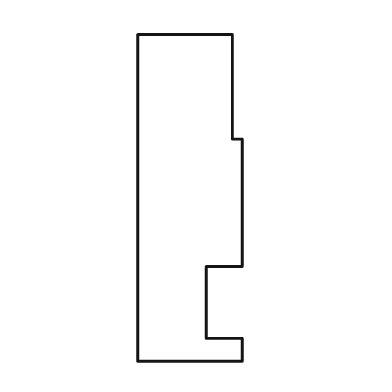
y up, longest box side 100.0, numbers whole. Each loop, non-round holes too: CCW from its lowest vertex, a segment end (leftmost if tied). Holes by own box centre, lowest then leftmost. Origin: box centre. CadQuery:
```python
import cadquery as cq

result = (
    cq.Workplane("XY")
    .moveTo(-16.0, -50.0)
    .lineTo(16.0, -50.0)
    .lineTo(16.0, -43.0)
    .lineTo(5.0, -43.0)
    .lineTo(5.0, -21.0)
    .lineTo(16.0, -21.0)
    .lineTo(16.0, 18.0)
    .lineTo(13.0, 18.0)
    .lineTo(13.0, 50.0)
    .lineTo(-16.0, 50.0)
    .close()
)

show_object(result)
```